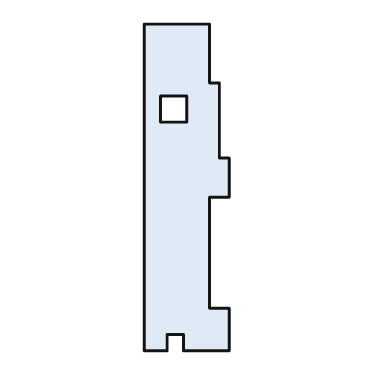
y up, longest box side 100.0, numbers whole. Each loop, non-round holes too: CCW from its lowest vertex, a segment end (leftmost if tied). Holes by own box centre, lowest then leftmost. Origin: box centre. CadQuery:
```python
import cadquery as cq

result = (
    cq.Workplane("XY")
    .moveTo(-13.0, -50.0)
    .lineTo(-6.0, -50.0)
    .lineTo(-6.0, -45.0)
    .lineTo(-1.0, -45.0)
    .lineTo(-1.0, -50.0)
    .lineTo(13.0, -50.0)
    .lineTo(13.0, -37.0)
    .lineTo(7.0, -37.0)
    .lineTo(7.0, -3.0)
    .lineTo(13.0, -3.0)
    .lineTo(13.0, 9.0)
    .lineTo(10.0, 9.0)
    .lineTo(10.0, 32.0)
    .lineTo(7.0, 32.0)
    .lineTo(7.0, 50.0)
    .lineTo(-13.0, 50.0)
    .close()
    .moveTo(-8.0, 20.0)
    .lineTo(0.0, 20.0)
    .lineTo(0.0, 28.0)
    .lineTo(-8.0, 28.0)
    .close()
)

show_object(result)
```